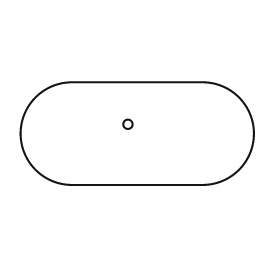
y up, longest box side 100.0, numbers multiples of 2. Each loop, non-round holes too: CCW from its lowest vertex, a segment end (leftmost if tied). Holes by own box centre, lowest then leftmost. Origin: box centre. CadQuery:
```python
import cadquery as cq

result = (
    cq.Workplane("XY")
    .moveTo(-28.0, -22.0)
    .lineTo(28.0, -22.0)
    .threePointArc((50.0, 0.0), (28.0, 22.0))
    .lineTo(-28.0, 22.0)
    .threePointArc((-50.0, 0.0), (-28.0, -22.0))
    .close()
    .moveTo(-4.0, 4.0)
    .circle(2.0)
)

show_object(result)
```